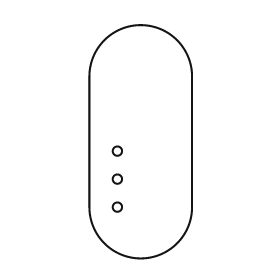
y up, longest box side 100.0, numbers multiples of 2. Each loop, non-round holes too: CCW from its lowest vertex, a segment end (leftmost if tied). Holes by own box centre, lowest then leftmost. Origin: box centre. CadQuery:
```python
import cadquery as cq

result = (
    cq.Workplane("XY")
    .moveTo(-22.0, -28.0)
    .threePointArc((0.0, -50.0), (22.0, -28.0))
    .lineTo(22.0, 28.0)
    .threePointArc((0.0, 50.0), (-22.0, 28.0))
    .close()
    .moveTo(-10.0, -28.0)
    .circle(2.0)
    .moveTo(-10.0, -16.0)
    .circle(2.0)
    .moveTo(-10.0, -4.0)
    .circle(2.0)
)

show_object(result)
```